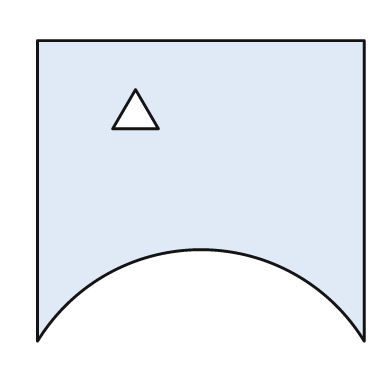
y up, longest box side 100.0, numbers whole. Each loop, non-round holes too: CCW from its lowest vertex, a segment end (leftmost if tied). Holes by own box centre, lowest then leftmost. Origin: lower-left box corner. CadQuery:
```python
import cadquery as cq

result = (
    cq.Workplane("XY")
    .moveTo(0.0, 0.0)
    .threePointArc((50.0, 28.0), (100.0, 0.0))
    .lineTo(100.0, 92.0)
    .lineTo(0.0, 92.0)
    .close()
    .moveTo(23.0, 65.0)
    .lineTo(37.0, 65.0)
    .lineTo(30.0, 77.0)
    .close()
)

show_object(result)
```